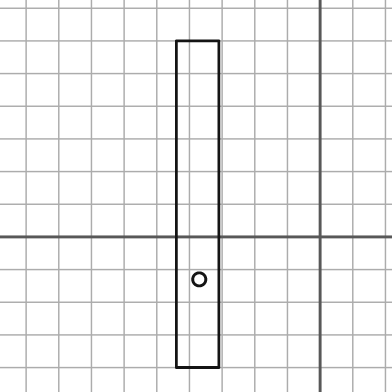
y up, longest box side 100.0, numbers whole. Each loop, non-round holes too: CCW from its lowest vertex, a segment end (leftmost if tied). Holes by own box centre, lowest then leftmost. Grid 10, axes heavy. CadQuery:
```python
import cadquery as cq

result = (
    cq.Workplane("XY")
    .moveTo(-44.0, -40.0)
    .lineTo(-31.0, -40.0)
    .lineTo(-31.0, 60.0)
    .lineTo(-44.0, 60.0)
    .close()
    .moveTo(-37.0, -13.0)
    .circle(2.0)
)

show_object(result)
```